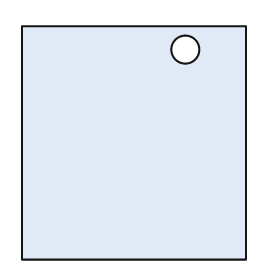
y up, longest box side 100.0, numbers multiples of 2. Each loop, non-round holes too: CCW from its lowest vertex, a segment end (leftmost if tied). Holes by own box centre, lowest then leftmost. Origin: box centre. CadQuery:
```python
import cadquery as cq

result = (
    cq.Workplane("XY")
    .moveTo(-48.0, -50.0)
    .lineTo(48.0, -50.0)
    .lineTo(48.0, 50.0)
    .lineTo(-48.0, 50.0)
    .close()
    .moveTo(22.0, 40.0)
    .circle(6.0)
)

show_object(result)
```